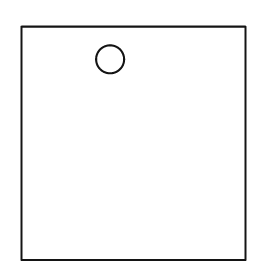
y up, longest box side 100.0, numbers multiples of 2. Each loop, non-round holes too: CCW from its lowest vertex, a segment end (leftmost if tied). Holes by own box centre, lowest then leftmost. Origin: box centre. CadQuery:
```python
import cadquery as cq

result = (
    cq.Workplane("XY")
    .moveTo(-48.0, -50.0)
    .lineTo(48.0, -50.0)
    .lineTo(48.0, 50.0)
    .lineTo(-48.0, 50.0)
    .close()
    .moveTo(-10.0, 36.0)
    .circle(6.0)
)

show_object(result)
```